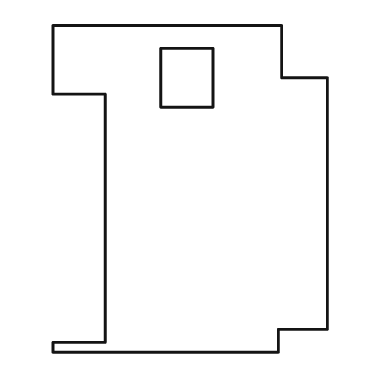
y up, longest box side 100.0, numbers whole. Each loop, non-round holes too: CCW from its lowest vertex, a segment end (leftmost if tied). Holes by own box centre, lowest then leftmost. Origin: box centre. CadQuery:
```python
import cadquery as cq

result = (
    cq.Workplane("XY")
    .moveTo(-42.0, -50.0)
    .lineTo(27.0, -50.0)
    .lineTo(27.0, -43.0)
    .lineTo(42.0, -43.0)
    .lineTo(42.0, 34.0)
    .lineTo(28.0, 34.0)
    .lineTo(28.0, 50.0)
    .lineTo(-42.0, 50.0)
    .lineTo(-42.0, 29.0)
    .lineTo(-26.0, 29.0)
    .lineTo(-26.0, -47.0)
    .lineTo(-42.0, -47.0)
    .close()
    .moveTo(-9.0, 25.0)
    .lineTo(7.0, 25.0)
    .lineTo(7.0, 43.0)
    .lineTo(-9.0, 43.0)
    .close()
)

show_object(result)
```